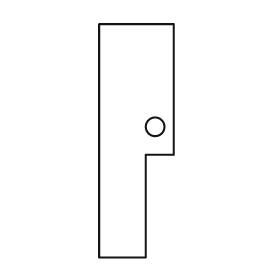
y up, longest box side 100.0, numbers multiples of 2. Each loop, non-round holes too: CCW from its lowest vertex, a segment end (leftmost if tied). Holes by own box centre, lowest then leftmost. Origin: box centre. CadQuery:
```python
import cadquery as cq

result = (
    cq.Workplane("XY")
    .moveTo(-16.0, -50.0)
    .lineTo(4.0, -50.0)
    .lineTo(4.0, -6.0)
    .lineTo(16.0, -6.0)
    .lineTo(16.0, 50.0)
    .lineTo(-16.0, 50.0)
    .close()
    .moveTo(8.0, 6.0)
    .circle(4.0)
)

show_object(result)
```